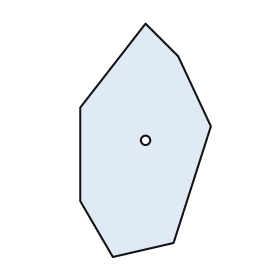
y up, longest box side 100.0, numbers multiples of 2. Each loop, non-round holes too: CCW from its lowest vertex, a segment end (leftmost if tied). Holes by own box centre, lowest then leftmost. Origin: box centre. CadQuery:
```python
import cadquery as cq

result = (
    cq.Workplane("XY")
    .moveTo(-14.0, -50.0)
    .lineTo(12.0, -44.0)
    .lineTo(28.0, 6.0)
    .lineTo(14.0, 36.0)
    .lineTo(0.0, 50.0)
    .lineTo(-28.0, 14.0)
    .lineTo(-28.0, -26.0)
    .close()
    .moveTo(0.0, 0.0)
    .circle(2.0)
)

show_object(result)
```